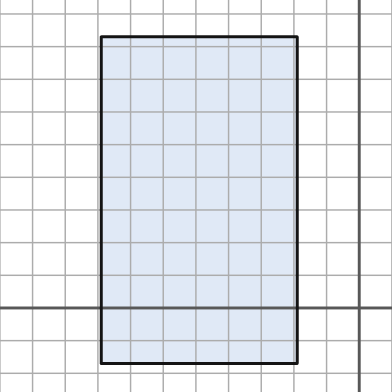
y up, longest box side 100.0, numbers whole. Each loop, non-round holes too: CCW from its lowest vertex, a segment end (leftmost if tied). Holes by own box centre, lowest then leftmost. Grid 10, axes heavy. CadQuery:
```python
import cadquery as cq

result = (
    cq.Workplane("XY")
    .moveTo(-79.0, -17.0)
    .lineTo(-19.0, -17.0)
    .lineTo(-19.0, 83.0)
    .lineTo(-79.0, 83.0)
    .close()
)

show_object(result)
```